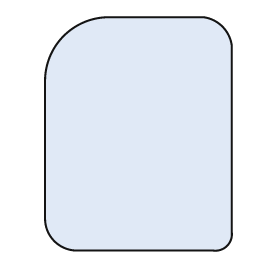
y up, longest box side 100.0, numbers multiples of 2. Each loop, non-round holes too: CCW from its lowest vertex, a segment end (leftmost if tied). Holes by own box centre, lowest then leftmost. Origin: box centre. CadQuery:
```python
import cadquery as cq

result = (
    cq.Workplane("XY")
    .moveTo(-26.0, -50.0)
    .lineTo(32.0, -50.0)
    .threePointArc((38.0, -48.0), (40.0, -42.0))
    .lineTo(40.0, 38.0)
    .threePointArc((36.0, 46.0), (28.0, 50.0))
    .lineTo(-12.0, 50.0)
    .threePointArc((-32.0, 42.0), (-40.0, 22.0))
    .lineTo(-40.0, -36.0)
    .threePointArc((-36.0, -46.0), (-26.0, -50.0))
    .close()
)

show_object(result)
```